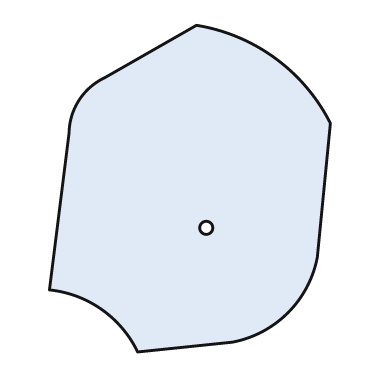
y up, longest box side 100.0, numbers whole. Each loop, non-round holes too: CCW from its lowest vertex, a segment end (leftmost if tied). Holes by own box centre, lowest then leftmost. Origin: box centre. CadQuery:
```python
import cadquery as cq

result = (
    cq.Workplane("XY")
    .moveTo(-16.0, -50.0)
    .lineTo(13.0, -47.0)
    .threePointArc((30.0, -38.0), (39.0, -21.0))
    .lineTo(43.0, 20.0)
    .threePointArc((26.0, 40.0), (2.0, 50.0))
    .lineTo(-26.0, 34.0)
    .threePointArc((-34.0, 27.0), (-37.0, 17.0))
    .lineTo(-43.0, -31.0)
    .threePointArc((-27.0, -37.0), (-16.0, -50.0))
    .close()
    .moveTo(5.0, -12.0)
    .circle(2.0)
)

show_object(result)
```